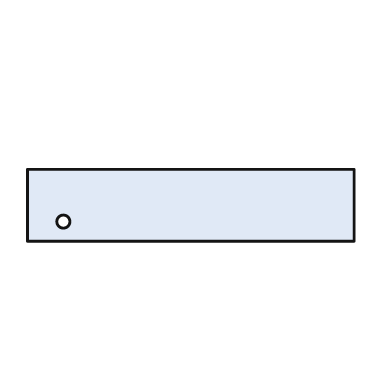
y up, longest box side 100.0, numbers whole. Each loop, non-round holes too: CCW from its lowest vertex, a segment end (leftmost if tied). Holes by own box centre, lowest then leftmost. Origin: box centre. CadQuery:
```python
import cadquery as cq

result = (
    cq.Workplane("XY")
    .moveTo(-50.0, -11.0)
    .lineTo(50.0, -11.0)
    .lineTo(50.0, 11.0)
    .lineTo(-50.0, 11.0)
    .close()
    .moveTo(-39.0, -5.0)
    .circle(2.0)
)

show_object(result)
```